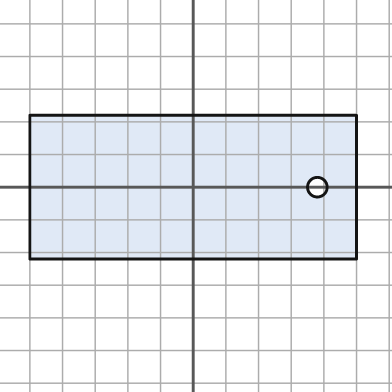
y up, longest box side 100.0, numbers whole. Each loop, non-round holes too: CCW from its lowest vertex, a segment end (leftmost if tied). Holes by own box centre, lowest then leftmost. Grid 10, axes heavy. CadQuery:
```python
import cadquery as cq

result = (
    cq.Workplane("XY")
    .moveTo(-50.0, -22.0)
    .lineTo(50.0, -22.0)
    .lineTo(50.0, 22.0)
    .lineTo(-50.0, 22.0)
    .close()
    .moveTo(38.0, 0.0)
    .circle(3.0)
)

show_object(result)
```